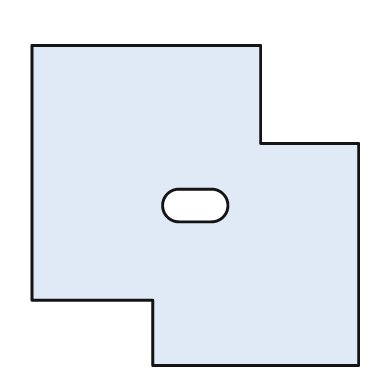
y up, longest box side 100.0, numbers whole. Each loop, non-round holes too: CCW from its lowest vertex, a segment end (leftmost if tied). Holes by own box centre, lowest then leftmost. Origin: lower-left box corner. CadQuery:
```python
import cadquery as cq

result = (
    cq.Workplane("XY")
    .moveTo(37.0, 0.0)
    .lineTo(100.0, 0.0)
    .lineTo(100.0, 68.0)
    .lineTo(70.0, 68.0)
    .lineTo(70.0, 98.0)
    .lineTo(0.0, 98.0)
    .lineTo(0.0, 20.0)
    .lineTo(37.0, 20.0)
    .close()
    .moveTo(45.0, 44.0)
    .lineTo(55.0, 44.0)
    .threePointArc((60.0, 49.0), (55.0, 54.0))
    .lineTo(45.0, 54.0)
    .threePointArc((40.0, 49.0), (45.0, 44.0))
    .close()
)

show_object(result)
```